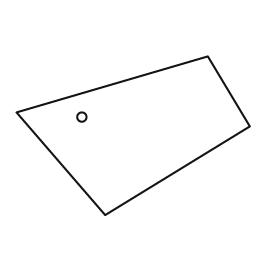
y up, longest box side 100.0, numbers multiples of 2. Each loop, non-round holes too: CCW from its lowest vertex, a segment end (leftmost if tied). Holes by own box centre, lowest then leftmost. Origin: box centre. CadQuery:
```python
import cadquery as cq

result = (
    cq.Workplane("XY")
    .moveTo(-12.0, -34.0)
    .lineTo(50.0, 4.0)
    .lineTo(32.0, 34.0)
    .lineTo(-50.0, 10.0)
    .close()
    .moveTo(-22.0, 8.0)
    .circle(2.0)
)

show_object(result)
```